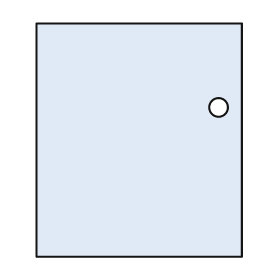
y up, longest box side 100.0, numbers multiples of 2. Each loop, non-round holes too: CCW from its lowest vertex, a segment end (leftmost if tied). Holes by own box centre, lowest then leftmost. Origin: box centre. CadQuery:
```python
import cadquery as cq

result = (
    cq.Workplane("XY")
    .moveTo(-44.0, -50.0)
    .lineTo(44.0, -50.0)
    .lineTo(44.0, 50.0)
    .lineTo(-44.0, 50.0)
    .close()
    .moveTo(34.0, 14.0)
    .circle(4.0)
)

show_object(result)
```